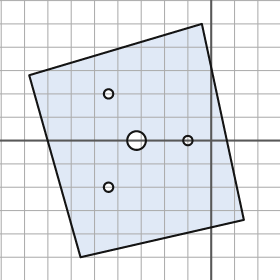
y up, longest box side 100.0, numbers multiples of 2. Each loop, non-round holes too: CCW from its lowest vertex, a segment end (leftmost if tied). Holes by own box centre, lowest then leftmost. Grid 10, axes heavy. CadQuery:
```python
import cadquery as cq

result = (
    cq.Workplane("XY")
    .moveTo(-56.0, -50.0)
    .lineTo(14.0, -34.0)
    .lineTo(-4.0, 50.0)
    .lineTo(-78.0, 28.0)
    .close()
    .moveTo(-44.0, -20.0)
    .circle(2.0)
    .moveTo(-32.0, 0.0)
    .circle(4.0)
    .moveTo(-10.0, 0.0)
    .circle(2.0)
    .moveTo(-44.0, 20.0)
    .circle(2.0)
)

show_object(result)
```